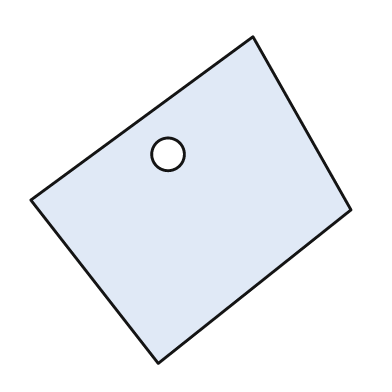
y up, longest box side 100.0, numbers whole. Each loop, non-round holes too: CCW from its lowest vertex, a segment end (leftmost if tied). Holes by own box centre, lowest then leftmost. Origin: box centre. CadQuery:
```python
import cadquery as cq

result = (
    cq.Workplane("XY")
    .moveTo(-10.0, -50.0)
    .lineTo(49.0, -3.0)
    .lineTo(19.0, 50.0)
    .lineTo(-49.0, 0.0)
    .close()
    .moveTo(-7.0, 14.0)
    .circle(5.0)
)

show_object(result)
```